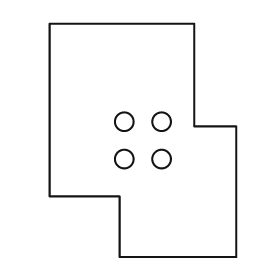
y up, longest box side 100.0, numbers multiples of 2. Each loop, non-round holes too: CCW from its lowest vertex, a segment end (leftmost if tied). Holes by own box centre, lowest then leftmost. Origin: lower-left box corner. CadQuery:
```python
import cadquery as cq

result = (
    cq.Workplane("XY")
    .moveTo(30.0, 0.0)
    .lineTo(80.0, 0.0)
    .lineTo(80.0, 56.0)
    .lineTo(62.0, 56.0)
    .lineTo(62.0, 100.0)
    .lineTo(0.0, 100.0)
    .lineTo(0.0, 26.0)
    .lineTo(30.0, 26.0)
    .close()
    .moveTo(32.0, 42.0)
    .circle(4.0)
    .moveTo(48.0, 42.0)
    .circle(4.0)
    .moveTo(32.0, 58.0)
    .circle(4.0)
    .moveTo(48.0, 58.0)
    .circle(4.0)
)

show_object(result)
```